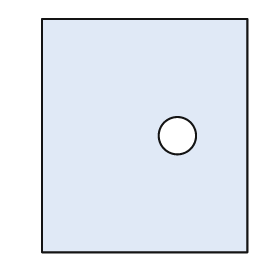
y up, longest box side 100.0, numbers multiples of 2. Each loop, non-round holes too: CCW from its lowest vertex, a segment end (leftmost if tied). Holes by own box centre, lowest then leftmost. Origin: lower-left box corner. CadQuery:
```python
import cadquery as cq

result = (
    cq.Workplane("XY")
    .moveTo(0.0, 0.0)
    .lineTo(88.0, 0.0)
    .lineTo(88.0, 100.0)
    .lineTo(0.0, 100.0)
    .close()
    .moveTo(58.0, 50.0)
    .circle(8.0)
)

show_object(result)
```